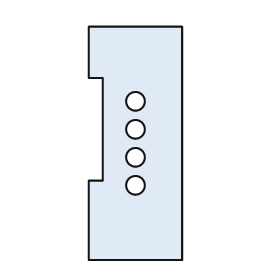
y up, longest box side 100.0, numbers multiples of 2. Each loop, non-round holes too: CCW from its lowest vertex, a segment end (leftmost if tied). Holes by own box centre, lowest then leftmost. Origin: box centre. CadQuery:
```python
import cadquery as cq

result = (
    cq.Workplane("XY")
    .moveTo(-20.0, -50.0)
    .lineTo(20.0, -50.0)
    .lineTo(20.0, 50.0)
    .lineTo(-20.0, 50.0)
    .lineTo(-20.0, 28.0)
    .lineTo(-14.0, 28.0)
    .lineTo(-14.0, -16.0)
    .lineTo(-20.0, -16.0)
    .close()
    .moveTo(0.0, -18.0)
    .circle(4.0)
    .moveTo(0.0, -6.0)
    .circle(4.0)
    .moveTo(0.0, 6.0)
    .circle(4.0)
    .moveTo(0.0, 18.0)
    .circle(4.0)
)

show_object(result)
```